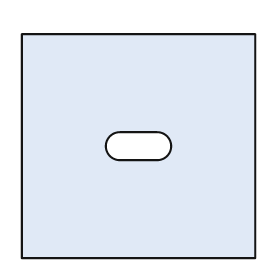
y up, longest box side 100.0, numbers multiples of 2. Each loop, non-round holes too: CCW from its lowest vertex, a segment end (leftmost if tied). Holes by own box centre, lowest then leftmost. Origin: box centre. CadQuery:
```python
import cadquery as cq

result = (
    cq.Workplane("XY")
    .moveTo(-50.0, -48.0)
    .lineTo(50.0, -48.0)
    .lineTo(50.0, 48.0)
    .lineTo(-50.0, 48.0)
    .close()
    .moveTo(-8.0, -6.0)
    .lineTo(8.0, -6.0)
    .threePointArc((14.0, 0.0), (8.0, 6.0))
    .lineTo(-8.0, 6.0)
    .threePointArc((-14.0, 0.0), (-8.0, -6.0))
    .close()
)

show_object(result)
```